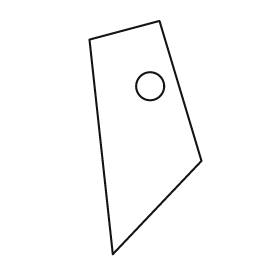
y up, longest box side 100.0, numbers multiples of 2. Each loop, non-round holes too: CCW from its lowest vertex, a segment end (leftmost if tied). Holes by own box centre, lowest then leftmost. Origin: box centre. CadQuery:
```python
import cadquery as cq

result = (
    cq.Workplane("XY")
    .moveTo(-14.0, -50.0)
    .lineTo(24.0, -10.0)
    .lineTo(6.0, 50.0)
    .lineTo(-24.0, 42.0)
    .close()
    .moveTo(2.0, 22.0)
    .circle(6.0)
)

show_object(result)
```